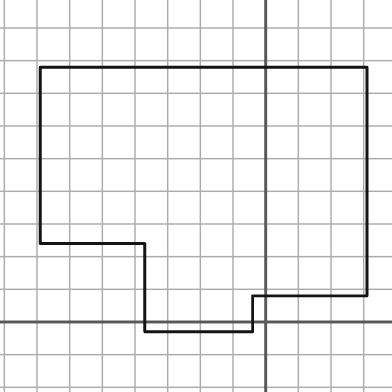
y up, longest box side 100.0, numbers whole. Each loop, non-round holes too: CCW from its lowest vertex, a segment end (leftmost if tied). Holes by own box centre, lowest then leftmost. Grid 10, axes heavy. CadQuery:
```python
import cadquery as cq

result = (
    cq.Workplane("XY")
    .moveTo(-37.0, -3.0)
    .lineTo(-4.0, -3.0)
    .lineTo(-4.0, 8.0)
    .lineTo(31.0, 8.0)
    .lineTo(31.0, 78.0)
    .lineTo(-69.0, 78.0)
    .lineTo(-69.0, 24.0)
    .lineTo(-37.0, 24.0)
    .close()
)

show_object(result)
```